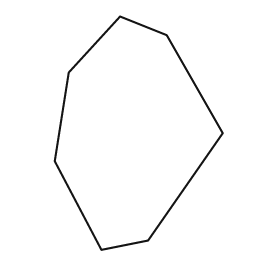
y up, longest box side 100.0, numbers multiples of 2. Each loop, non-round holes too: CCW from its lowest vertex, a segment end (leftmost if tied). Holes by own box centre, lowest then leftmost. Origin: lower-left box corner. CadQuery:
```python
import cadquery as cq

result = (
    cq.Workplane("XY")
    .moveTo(20.0, 0.0)
    .lineTo(40.0, 4.0)
    .lineTo(72.0, 50.0)
    .lineTo(48.0, 92.0)
    .lineTo(28.0, 100.0)
    .lineTo(6.0, 76.0)
    .lineTo(0.0, 38.0)
    .close()
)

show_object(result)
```